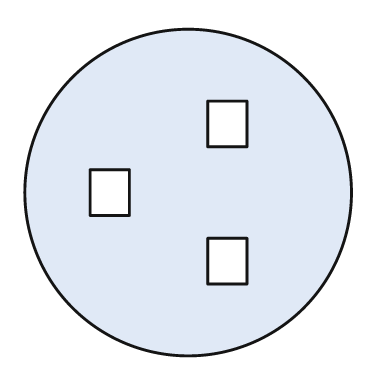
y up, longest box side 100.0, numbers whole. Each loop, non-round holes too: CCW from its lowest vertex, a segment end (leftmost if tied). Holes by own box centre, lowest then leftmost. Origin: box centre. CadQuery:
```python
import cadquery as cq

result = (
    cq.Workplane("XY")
    .moveTo(0.0, 0.0)
    .circle(50.0)
    .moveTo(6.0, -28.0)
    .lineTo(18.0, -28.0)
    .lineTo(18.0, -14.0)
    .lineTo(6.0, -14.0)
    .close()
    .moveTo(-30.0, -7.0)
    .lineTo(-18.0, -7.0)
    .lineTo(-18.0, 7.0)
    .lineTo(-30.0, 7.0)
    .close()
    .moveTo(6.0, 14.0)
    .lineTo(18.0, 14.0)
    .lineTo(18.0, 28.0)
    .lineTo(6.0, 28.0)
    .close()
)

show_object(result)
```